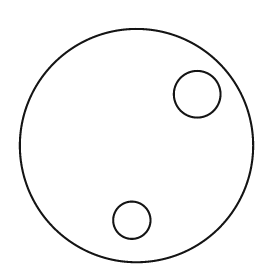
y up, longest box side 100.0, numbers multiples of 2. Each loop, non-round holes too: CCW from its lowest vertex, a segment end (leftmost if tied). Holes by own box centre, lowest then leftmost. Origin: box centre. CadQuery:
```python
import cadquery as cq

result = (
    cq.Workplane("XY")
    .moveTo(0.0, 0.0)
    .circle(50.0)
    .moveTo(-2.0, -32.0)
    .circle(8.0)
    .moveTo(26.0, 22.0)
    .circle(10.0)
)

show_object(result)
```